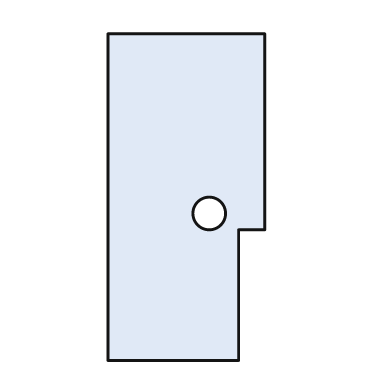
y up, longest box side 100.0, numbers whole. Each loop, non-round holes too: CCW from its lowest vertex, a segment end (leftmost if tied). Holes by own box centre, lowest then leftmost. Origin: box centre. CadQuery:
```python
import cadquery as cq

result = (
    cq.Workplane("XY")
    .moveTo(-24.0, -50.0)
    .lineTo(16.0, -50.0)
    .lineTo(16.0, -10.0)
    .lineTo(24.0, -10.0)
    .lineTo(24.0, 50.0)
    .lineTo(-24.0, 50.0)
    .close()
    .moveTo(7.0, -5.0)
    .circle(5.0)
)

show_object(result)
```